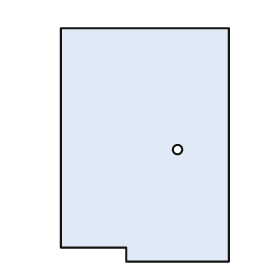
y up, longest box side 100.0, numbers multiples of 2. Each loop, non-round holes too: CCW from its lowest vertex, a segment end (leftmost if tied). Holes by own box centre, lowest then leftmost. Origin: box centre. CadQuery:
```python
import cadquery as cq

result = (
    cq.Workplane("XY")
    .moveTo(-8.0, -50.0)
    .lineTo(36.0, -50.0)
    .lineTo(36.0, 50.0)
    .lineTo(-36.0, 50.0)
    .lineTo(-36.0, -44.0)
    .lineTo(-8.0, -44.0)
    .close()
    .moveTo(14.0, -2.0)
    .circle(2.0)
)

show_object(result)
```